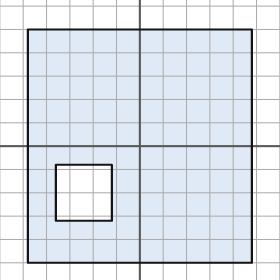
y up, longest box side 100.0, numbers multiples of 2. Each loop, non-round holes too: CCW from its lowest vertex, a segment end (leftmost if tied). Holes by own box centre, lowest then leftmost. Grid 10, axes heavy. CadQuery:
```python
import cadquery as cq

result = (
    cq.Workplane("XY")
    .moveTo(-48.0, -50.0)
    .lineTo(48.0, -50.0)
    .lineTo(48.0, 50.0)
    .lineTo(-48.0, 50.0)
    .close()
    .moveTo(-36.0, -32.0)
    .lineTo(-12.0, -32.0)
    .lineTo(-12.0, -8.0)
    .lineTo(-36.0, -8.0)
    .close()
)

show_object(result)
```